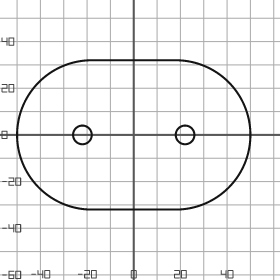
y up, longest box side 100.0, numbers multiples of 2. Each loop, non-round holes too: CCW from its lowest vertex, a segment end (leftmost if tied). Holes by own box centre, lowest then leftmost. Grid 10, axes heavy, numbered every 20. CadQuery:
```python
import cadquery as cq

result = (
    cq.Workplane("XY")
    .moveTo(-18.0, -32.0)
    .lineTo(18.0, -32.0)
    .threePointArc((50.0, 0.0), (18.0, 32.0))
    .lineTo(-18.0, 32.0)
    .threePointArc((-50.0, 0.0), (-18.0, -32.0))
    .close()
    .moveTo(-22.0, 0.0)
    .circle(4.0)
    .moveTo(22.0, 0.0)
    .circle(4.0)
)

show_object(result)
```